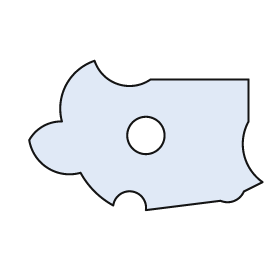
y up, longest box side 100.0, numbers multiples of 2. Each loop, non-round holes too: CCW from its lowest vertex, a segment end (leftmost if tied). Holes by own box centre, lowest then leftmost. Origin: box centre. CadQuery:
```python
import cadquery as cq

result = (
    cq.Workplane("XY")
    .moveTo(0.0, -32.0)
    .lineTo(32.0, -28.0)
    .threePointArc((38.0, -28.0), (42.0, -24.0))
    .lineTo(50.0, -20.0)
    .threePointArc((42.0, -8.0), (44.0, 6.0))
    .lineTo(44.0, 24.0)
    .lineTo(2.0, 24.0)
    .threePointArc((-12.0, 22.0), (-22.0, 32.0))
    .threePointArc((-34.0, 22.0), (-36.0, 6.0))
    .threePointArc((-44.0, 4.0), (-50.0, -2.0))
    .threePointArc((-42.0, -14.0), (-28.0, -16.0))
    .threePointArc((-22.0, -24.0), (-14.0, -30.0))
    .threePointArc((-6.0, -24.0), (0.0, -32.0))
    .close()
    .moveTo(0.0, 0.0)
    .circle(8.0)
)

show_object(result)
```